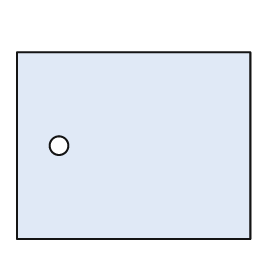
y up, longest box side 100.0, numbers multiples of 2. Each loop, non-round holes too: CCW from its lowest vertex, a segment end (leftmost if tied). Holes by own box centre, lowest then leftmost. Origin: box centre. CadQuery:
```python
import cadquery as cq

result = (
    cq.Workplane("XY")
    .moveTo(-50.0, -40.0)
    .lineTo(50.0, -40.0)
    .lineTo(50.0, 40.0)
    .lineTo(-50.0, 40.0)
    .close()
    .moveTo(-32.0, 0.0)
    .circle(4.0)
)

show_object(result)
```